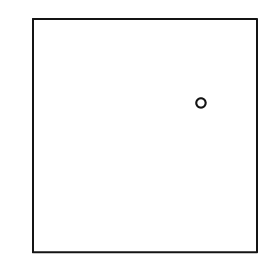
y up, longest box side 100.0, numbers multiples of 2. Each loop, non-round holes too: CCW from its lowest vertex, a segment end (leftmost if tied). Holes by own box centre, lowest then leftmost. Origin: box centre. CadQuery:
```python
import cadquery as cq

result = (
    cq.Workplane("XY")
    .moveTo(-48.0, -50.0)
    .lineTo(48.0, -50.0)
    .lineTo(48.0, 50.0)
    .lineTo(-48.0, 50.0)
    .close()
    .moveTo(24.0, 14.0)
    .circle(2.0)
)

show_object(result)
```